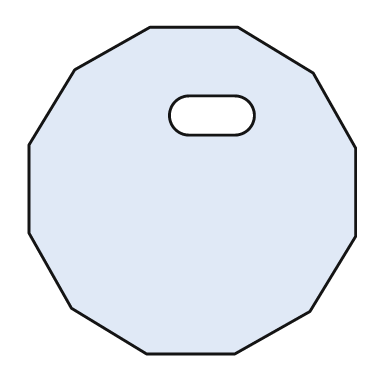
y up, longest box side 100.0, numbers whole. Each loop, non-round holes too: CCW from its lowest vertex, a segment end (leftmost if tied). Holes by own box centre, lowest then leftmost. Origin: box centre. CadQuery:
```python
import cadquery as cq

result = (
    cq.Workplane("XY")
    .moveTo(-14.0, -50.0)
    .lineTo(13.0, -50.0)
    .lineTo(36.0, -37.0)
    .lineTo(50.0, -14.0)
    .lineTo(50.0, 13.0)
    .lineTo(37.0, 36.0)
    .lineTo(14.0, 50.0)
    .lineTo(-13.0, 50.0)
    .lineTo(-36.0, 37.0)
    .lineTo(-50.0, 14.0)
    .lineTo(-50.0, -13.0)
    .lineTo(-37.0, -36.0)
    .close()
    .moveTo(-1.0, 17.0)
    .lineTo(13.0, 17.0)
    .threePointArc((19.0, 23.0), (13.0, 29.0))
    .lineTo(-1.0, 29.0)
    .threePointArc((-7.0, 23.0), (-1.0, 17.0))
    .close()
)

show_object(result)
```